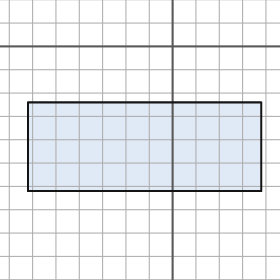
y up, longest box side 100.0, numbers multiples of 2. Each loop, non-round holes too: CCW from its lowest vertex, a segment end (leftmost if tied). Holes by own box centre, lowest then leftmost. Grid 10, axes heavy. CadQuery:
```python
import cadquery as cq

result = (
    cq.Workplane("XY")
    .moveTo(-62.0, -62.0)
    .lineTo(38.0, -62.0)
    .lineTo(38.0, -24.0)
    .lineTo(-62.0, -24.0)
    .close()
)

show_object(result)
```